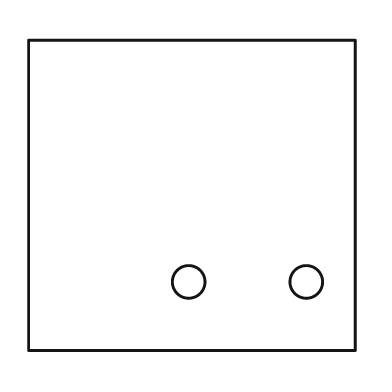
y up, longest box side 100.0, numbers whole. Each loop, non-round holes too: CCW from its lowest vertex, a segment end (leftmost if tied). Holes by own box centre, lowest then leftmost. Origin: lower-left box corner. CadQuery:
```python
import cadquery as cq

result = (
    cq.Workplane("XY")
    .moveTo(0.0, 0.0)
    .lineTo(100.0, 0.0)
    .lineTo(100.0, 95.0)
    .lineTo(0.0, 95.0)
    .close()
    .moveTo(49.0, 21.0)
    .circle(5.0)
    .moveTo(85.0, 21.0)
    .circle(5.0)
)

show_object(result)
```